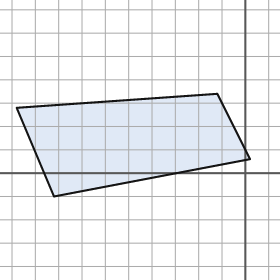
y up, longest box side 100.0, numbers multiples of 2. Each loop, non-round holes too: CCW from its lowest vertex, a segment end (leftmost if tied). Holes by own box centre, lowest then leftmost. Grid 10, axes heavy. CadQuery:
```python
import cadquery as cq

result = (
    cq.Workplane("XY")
    .moveTo(-82.0, -10.0)
    .lineTo(2.0, 6.0)
    .lineTo(-12.0, 34.0)
    .lineTo(-98.0, 28.0)
    .close()
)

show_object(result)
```